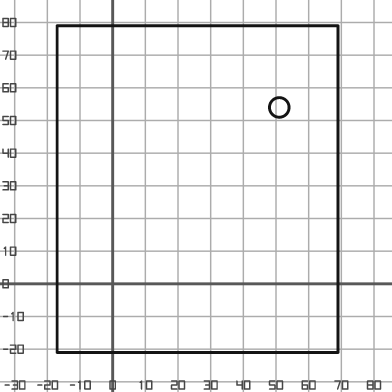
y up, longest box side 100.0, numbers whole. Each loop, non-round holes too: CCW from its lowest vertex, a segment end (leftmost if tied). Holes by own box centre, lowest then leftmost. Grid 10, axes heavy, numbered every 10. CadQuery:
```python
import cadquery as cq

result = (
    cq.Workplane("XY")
    .moveTo(-17.0, -21.0)
    .lineTo(69.0, -21.0)
    .lineTo(69.0, 79.0)
    .lineTo(-17.0, 79.0)
    .close()
    .moveTo(51.0, 54.0)
    .circle(3.0)
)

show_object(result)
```